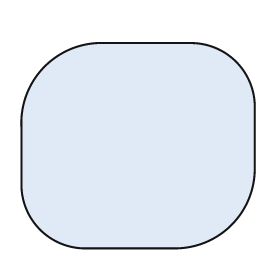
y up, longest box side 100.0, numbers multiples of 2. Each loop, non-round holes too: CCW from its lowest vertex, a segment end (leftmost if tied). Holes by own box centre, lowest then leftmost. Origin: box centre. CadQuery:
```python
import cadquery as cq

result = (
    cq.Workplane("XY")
    .moveTo(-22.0, -44.0)
    .lineTo(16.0, -44.0)
    .threePointArc((40.0, -34.0), (50.0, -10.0))
    .lineTo(50.0, 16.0)
    .threePointArc((42.0, 36.0), (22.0, 44.0))
    .lineTo(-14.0, 44.0)
    .threePointArc((-40.0, 34.0), (-50.0, 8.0))
    .lineTo(-50.0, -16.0)
    .threePointArc((-42.0, -36.0), (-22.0, -44.0))
    .close()
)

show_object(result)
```